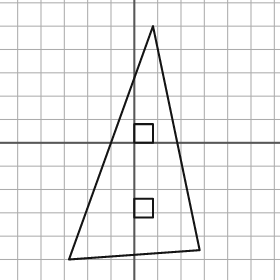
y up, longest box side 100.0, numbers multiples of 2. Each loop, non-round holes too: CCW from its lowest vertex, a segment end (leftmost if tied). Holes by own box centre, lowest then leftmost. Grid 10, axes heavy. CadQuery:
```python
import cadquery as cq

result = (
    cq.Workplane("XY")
    .moveTo(-28.0, -50.0)
    .lineTo(28.0, -46.0)
    .lineTo(8.0, 50.0)
    .close()
    .moveTo(0.0, -32.0)
    .lineTo(8.0, -32.0)
    .lineTo(8.0, -24.0)
    .lineTo(0.0, -24.0)
    .close()
    .moveTo(0.0, 0.0)
    .lineTo(8.0, 0.0)
    .lineTo(8.0, 8.0)
    .lineTo(0.0, 8.0)
    .close()
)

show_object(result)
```